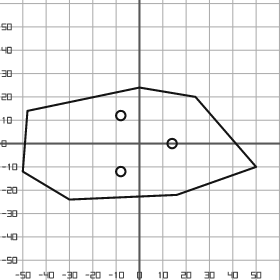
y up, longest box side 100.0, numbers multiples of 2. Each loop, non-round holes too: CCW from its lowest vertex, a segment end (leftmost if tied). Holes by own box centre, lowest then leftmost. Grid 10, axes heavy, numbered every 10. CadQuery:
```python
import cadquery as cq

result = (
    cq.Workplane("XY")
    .moveTo(-30.0, -24.0)
    .lineTo(16.0, -22.0)
    .lineTo(50.0, -10.0)
    .lineTo(24.0, 20.0)
    .lineTo(0.0, 24.0)
    .lineTo(-48.0, 14.0)
    .lineTo(-50.0, -12.0)
    .close()
    .moveTo(-8.0, -12.0)
    .circle(2.0)
    .moveTo(14.0, 0.0)
    .circle(2.0)
    .moveTo(-8.0, 12.0)
    .circle(2.0)
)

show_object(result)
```